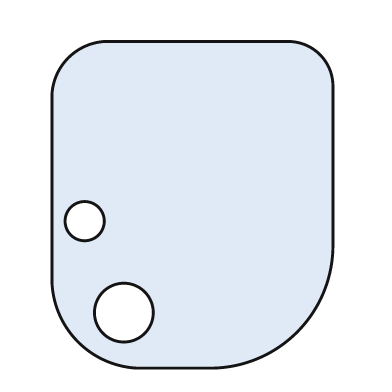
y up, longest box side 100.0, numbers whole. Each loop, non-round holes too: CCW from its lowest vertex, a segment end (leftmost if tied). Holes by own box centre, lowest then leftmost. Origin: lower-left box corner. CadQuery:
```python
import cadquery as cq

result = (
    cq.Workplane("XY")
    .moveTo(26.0, 0.0)
    .lineTo(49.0, 0.0)
    .threePointArc((75.0, 11.0), (86.0, 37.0))
    .lineTo(86.0, 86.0)
    .threePointArc((82.0, 96.0), (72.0, 100.0))
    .lineTo(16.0, 100.0)
    .threePointArc((5.0, 95.0), (0.0, 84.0))
    .lineTo(0.0, 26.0)
    .threePointArc((8.0, 8.0), (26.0, 0.0))
    .close()
    .moveTo(22.0, 17.0)
    .circle(9.0)
    .moveTo(10.0, 45.0)
    .circle(6.0)
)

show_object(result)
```